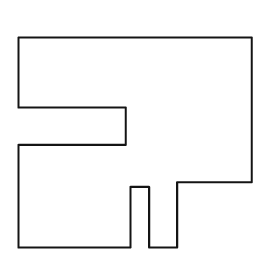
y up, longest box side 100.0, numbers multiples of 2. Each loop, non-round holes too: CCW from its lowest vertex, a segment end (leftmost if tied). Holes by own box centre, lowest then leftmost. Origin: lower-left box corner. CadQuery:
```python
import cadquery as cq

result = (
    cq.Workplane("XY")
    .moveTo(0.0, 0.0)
    .lineTo(48.0, 0.0)
    .lineTo(48.0, 26.0)
    .lineTo(56.0, 26.0)
    .lineTo(56.0, 0.0)
    .lineTo(68.0, 0.0)
    .lineTo(68.0, 28.0)
    .lineTo(100.0, 28.0)
    .lineTo(100.0, 90.0)
    .lineTo(0.0, 90.0)
    .lineTo(0.0, 60.0)
    .lineTo(46.0, 60.0)
    .lineTo(46.0, 44.0)
    .lineTo(0.0, 44.0)
    .close()
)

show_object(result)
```